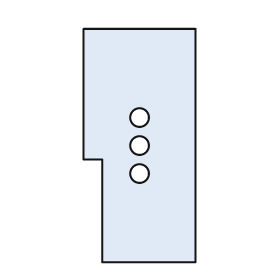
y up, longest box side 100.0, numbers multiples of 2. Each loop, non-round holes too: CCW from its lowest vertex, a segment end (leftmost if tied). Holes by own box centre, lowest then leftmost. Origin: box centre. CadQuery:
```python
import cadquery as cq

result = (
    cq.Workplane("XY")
    .moveTo(-16.0, -50.0)
    .lineTo(24.0, -50.0)
    .lineTo(24.0, 50.0)
    .lineTo(-24.0, 50.0)
    .lineTo(-24.0, -6.0)
    .lineTo(-16.0, -6.0)
    .close()
    .moveTo(0.0, -12.0)
    .circle(4.0)
    .moveTo(0.0, 0.0)
    .circle(4.0)
    .moveTo(0.0, 12.0)
    .circle(4.0)
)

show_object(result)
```